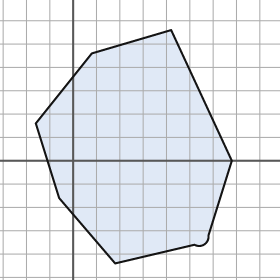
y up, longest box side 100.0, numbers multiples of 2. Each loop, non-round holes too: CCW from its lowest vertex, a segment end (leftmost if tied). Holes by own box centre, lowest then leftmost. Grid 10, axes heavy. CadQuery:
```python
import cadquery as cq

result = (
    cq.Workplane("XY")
    .moveTo(18.0, -44.0)
    .lineTo(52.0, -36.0)
    .threePointArc((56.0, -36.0), (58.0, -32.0))
    .lineTo(68.0, 0.0)
    .lineTo(42.0, 56.0)
    .lineTo(8.0, 46.0)
    .lineTo(-16.0, 16.0)
    .lineTo(-6.0, -16.0)
    .close()
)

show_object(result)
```